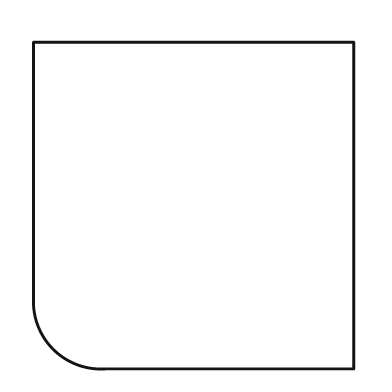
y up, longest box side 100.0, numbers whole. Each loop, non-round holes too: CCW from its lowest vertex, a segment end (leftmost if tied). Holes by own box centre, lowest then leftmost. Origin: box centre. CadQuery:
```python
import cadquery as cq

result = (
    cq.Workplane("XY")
    .moveTo(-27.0, -50.0)
    .lineTo(49.0, -50.0)
    .lineTo(49.0, 50.0)
    .lineTo(-49.0, 50.0)
    .lineTo(-49.0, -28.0)
    .threePointArc((-43.0, -44.0), (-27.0, -50.0))
    .close()
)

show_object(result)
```